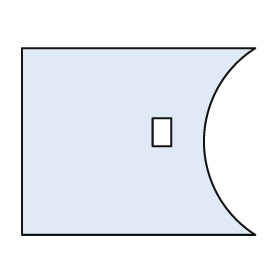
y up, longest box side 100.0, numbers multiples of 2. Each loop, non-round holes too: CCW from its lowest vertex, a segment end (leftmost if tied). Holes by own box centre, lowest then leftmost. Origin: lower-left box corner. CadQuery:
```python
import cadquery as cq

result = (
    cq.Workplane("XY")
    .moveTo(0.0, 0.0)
    .lineTo(100.0, 0.0)
    .threePointArc((78.0, 40.0), (100.0, 80.0))
    .lineTo(0.0, 80.0)
    .close()
    .moveTo(56.0, 38.0)
    .lineTo(64.0, 38.0)
    .lineTo(64.0, 50.0)
    .lineTo(56.0, 50.0)
    .close()
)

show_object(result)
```